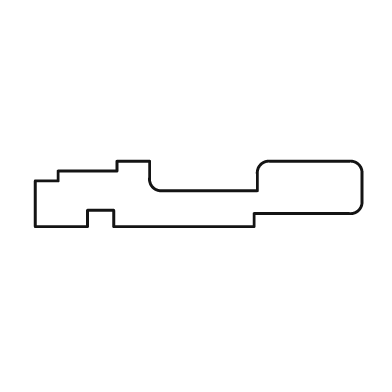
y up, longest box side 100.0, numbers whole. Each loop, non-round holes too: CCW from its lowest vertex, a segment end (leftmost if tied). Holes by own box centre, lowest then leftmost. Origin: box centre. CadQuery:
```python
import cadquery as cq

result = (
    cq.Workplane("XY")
    .moveTo(-50.0, -10.0)
    .lineTo(-34.0, -10.0)
    .lineTo(-34.0, -5.0)
    .lineTo(-26.0, -5.0)
    .lineTo(-26.0, -10.0)
    .lineTo(17.0, -10.0)
    .lineTo(17.0, -6.0)
    .lineTo(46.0, -6.0)
    .threePointArc((49.0, -5.0), (50.0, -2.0))
    .lineTo(50.0, 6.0)
    .threePointArc((49.0, 9.0), (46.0, 10.0))
    .lineTo(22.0, 10.0)
    .threePointArc((19.0, 9.0), (18.0, 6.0))
    .lineTo(18.0, 1.0)
    .lineTo(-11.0, 1.0)
    .threePointArc((-14.0, 2.0), (-15.0, 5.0))
    .lineTo(-15.0, 10.0)
    .lineTo(-25.0, 10.0)
    .lineTo(-25.0, 7.0)
    .lineTo(-43.0, 7.0)
    .lineTo(-43.0, 4.0)
    .lineTo(-50.0, 4.0)
    .close()
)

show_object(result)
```